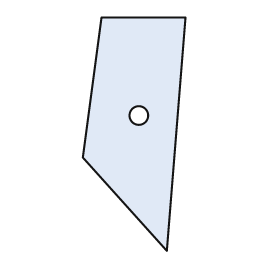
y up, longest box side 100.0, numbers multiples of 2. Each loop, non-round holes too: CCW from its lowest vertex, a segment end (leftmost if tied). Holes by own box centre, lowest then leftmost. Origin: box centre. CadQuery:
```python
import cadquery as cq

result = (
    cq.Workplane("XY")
    .moveTo(14.0, -50.0)
    .lineTo(22.0, 50.0)
    .lineTo(-14.0, 50.0)
    .lineTo(-22.0, -10.0)
    .close()
    .moveTo(2.0, 8.0)
    .circle(4.0)
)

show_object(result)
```